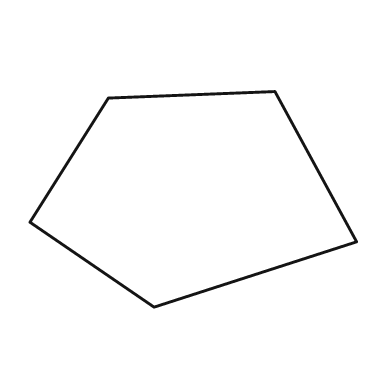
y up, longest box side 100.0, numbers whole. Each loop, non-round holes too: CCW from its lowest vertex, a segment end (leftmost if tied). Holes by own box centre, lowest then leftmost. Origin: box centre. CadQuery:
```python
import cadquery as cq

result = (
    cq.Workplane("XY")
    .moveTo(-12.0, -33.0)
    .lineTo(50.0, -13.0)
    .lineTo(25.0, 33.0)
    .lineTo(-26.0, 31.0)
    .lineTo(-50.0, -7.0)
    .close()
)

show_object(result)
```